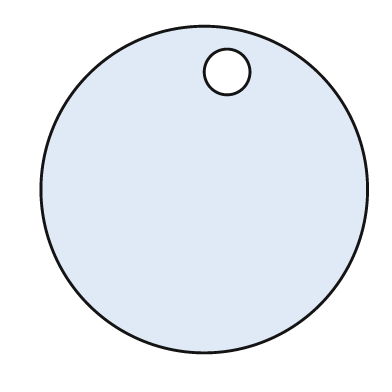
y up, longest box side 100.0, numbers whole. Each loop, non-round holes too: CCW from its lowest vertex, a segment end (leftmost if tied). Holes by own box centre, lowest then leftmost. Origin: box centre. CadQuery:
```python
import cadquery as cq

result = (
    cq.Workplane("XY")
    .moveTo(0.0, 0.0)
    .circle(50.0)
    .moveTo(7.0, 36.0)
    .circle(7.0)
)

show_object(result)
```